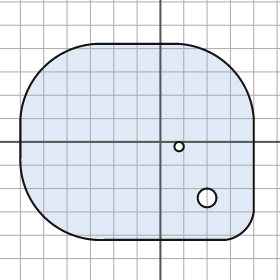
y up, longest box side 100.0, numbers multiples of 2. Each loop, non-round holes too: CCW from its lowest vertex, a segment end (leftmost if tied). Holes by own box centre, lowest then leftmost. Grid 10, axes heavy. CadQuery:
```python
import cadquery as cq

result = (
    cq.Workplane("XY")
    .moveTo(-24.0, -42.0)
    .lineTo(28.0, -42.0)
    .threePointArc((36.0, -38.0), (40.0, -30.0))
    .lineTo(40.0, 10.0)
    .threePointArc((30.0, 32.0), (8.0, 42.0))
    .lineTo(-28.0, 42.0)
    .threePointArc((-50.0, 32.0), (-60.0, 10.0))
    .lineTo(-60.0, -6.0)
    .threePointArc((-50.0, -32.0), (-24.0, -42.0))
    .close()
    .moveTo(20.0, -24.0)
    .circle(4.0)
    .moveTo(8.0, -2.0)
    .circle(2.0)
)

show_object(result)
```